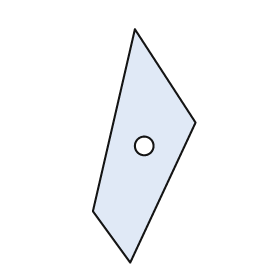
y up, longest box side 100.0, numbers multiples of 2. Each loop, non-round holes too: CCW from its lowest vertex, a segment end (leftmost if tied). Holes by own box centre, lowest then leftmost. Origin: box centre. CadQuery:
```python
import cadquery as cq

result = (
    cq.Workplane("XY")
    .moveTo(-6.0, -50.0)
    .lineTo(22.0, 10.0)
    .lineTo(-4.0, 50.0)
    .lineTo(-22.0, -28.0)
    .close()
    .moveTo(0.0, 0.0)
    .circle(4.0)
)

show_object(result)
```